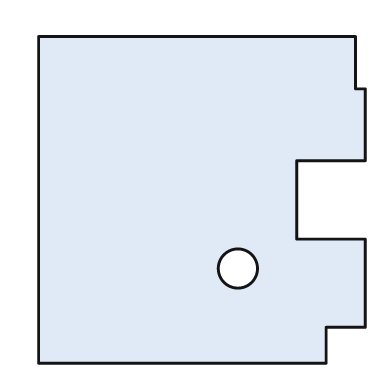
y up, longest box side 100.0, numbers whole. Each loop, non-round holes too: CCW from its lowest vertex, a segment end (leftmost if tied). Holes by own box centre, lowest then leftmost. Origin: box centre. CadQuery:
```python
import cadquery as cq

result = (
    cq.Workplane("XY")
    .moveTo(-50.0, -50.0)
    .lineTo(38.0, -50.0)
    .lineTo(38.0, -39.0)
    .lineTo(50.0, -39.0)
    .lineTo(50.0, -12.0)
    .lineTo(29.0, -12.0)
    .lineTo(29.0, 12.0)
    .lineTo(50.0, 12.0)
    .lineTo(50.0, 34.0)
    .lineTo(47.0, 34.0)
    .lineTo(47.0, 50.0)
    .lineTo(-50.0, 50.0)
    .close()
    .moveTo(11.0, -21.0)
    .circle(6.0)
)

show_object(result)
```